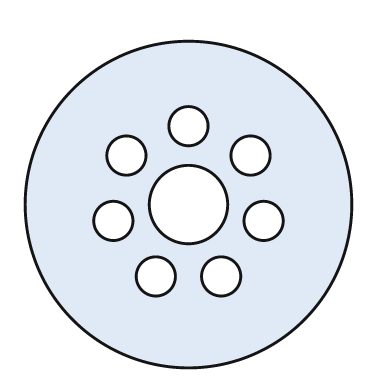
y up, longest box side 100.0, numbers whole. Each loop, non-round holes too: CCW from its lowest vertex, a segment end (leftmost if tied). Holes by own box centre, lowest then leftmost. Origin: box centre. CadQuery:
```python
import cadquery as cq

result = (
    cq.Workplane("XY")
    .moveTo(0.0, 0.0)
    .circle(50.0)
    .moveTo(-10.0, -22.0)
    .circle(6.0)
    .moveTo(10.0, -22.0)
    .circle(6.0)
    .moveTo(-23.0, -5.0)
    .circle(6.0)
    .moveTo(23.0, -5.0)
    .circle(6.0)
    .moveTo(0.0, 0.0)
    .circle(12.0)
    .moveTo(-19.0, 15.0)
    .circle(6.0)
    .moveTo(19.0, 15.0)
    .circle(6.0)
    .moveTo(0.0, 24.0)
    .circle(6.0)
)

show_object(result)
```